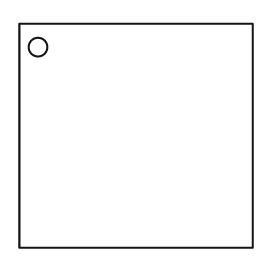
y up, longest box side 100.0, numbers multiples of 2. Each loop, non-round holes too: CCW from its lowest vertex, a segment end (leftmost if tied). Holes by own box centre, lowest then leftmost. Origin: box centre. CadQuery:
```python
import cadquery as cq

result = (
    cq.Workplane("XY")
    .moveTo(-50.0, -48.0)
    .lineTo(50.0, -48.0)
    .lineTo(50.0, 48.0)
    .lineTo(-50.0, 48.0)
    .close()
    .moveTo(-42.0, 38.0)
    .circle(4.0)
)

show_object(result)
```